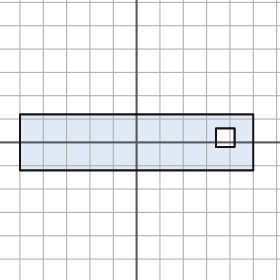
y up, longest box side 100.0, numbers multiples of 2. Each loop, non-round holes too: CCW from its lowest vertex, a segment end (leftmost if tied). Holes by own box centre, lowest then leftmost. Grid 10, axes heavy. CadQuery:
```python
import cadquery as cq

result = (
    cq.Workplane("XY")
    .moveTo(-50.0, -12.0)
    .lineTo(50.0, -12.0)
    .lineTo(50.0, 12.0)
    .lineTo(-50.0, 12.0)
    .close()
    .moveTo(34.0, -2.0)
    .lineTo(42.0, -2.0)
    .lineTo(42.0, 6.0)
    .lineTo(34.0, 6.0)
    .close()
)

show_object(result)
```